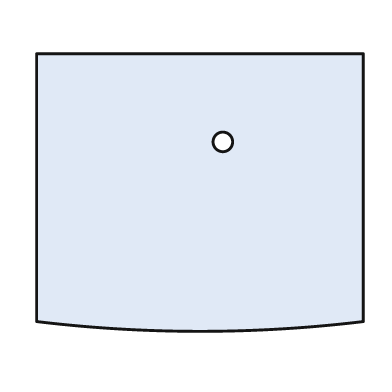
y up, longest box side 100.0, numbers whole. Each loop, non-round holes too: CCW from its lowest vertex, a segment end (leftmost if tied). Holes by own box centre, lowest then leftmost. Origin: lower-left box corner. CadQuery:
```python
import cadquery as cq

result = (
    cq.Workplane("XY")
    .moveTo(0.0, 3.0)
    .threePointArc((50.0, 0.0), (100.0, 3.0))
    .lineTo(100.0, 85.0)
    .lineTo(0.0, 85.0)
    .close()
    .moveTo(57.0, 58.0)
    .circle(3.0)
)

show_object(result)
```